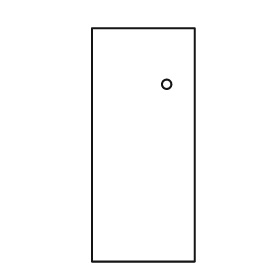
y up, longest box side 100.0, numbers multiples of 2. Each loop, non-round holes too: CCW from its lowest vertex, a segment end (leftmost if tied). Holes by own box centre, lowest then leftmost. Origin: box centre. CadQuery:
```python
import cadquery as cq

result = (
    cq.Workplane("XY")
    .moveTo(-22.0, -50.0)
    .lineTo(22.0, -50.0)
    .lineTo(22.0, 50.0)
    .lineTo(-22.0, 50.0)
    .close()
    .moveTo(10.0, 26.0)
    .circle(2.0)
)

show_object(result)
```